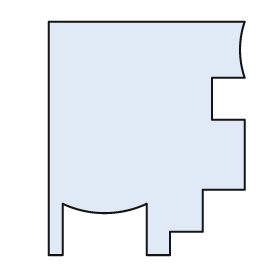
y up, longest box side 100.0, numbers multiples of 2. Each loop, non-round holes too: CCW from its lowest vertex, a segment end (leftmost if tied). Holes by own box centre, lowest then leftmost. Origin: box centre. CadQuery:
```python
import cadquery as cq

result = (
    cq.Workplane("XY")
    .moveTo(-42.0, -50.0)
    .lineTo(-36.0, -50.0)
    .lineTo(-36.0, -28.0)
    .threePointArc((-18.0, -32.0), (0.0, -28.0))
    .lineTo(0.0, -50.0)
    .lineTo(10.0, -50.0)
    .lineTo(10.0, -40.0)
    .lineTo(24.0, -40.0)
    .lineTo(24.0, -22.0)
    .lineTo(42.0, -22.0)
    .lineTo(42.0, 8.0)
    .lineTo(28.0, 8.0)
    .lineTo(28.0, 26.0)
    .lineTo(42.0, 26.0)
    .threePointArc((40.0, 38.0), (42.0, 50.0))
    .lineTo(-42.0, 50.0)
    .close()
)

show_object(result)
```